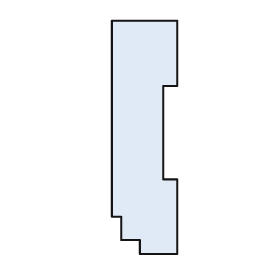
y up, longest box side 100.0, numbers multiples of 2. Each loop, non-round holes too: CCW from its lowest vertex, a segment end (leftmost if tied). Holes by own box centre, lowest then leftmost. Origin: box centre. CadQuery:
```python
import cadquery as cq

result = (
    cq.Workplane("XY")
    .moveTo(-2.0, -50.0)
    .lineTo(14.0, -50.0)
    .lineTo(14.0, -18.0)
    .lineTo(8.0, -18.0)
    .lineTo(8.0, 22.0)
    .lineTo(14.0, 22.0)
    .lineTo(14.0, 50.0)
    .lineTo(-14.0, 50.0)
    .lineTo(-14.0, -34.0)
    .lineTo(-10.0, -34.0)
    .lineTo(-10.0, -44.0)
    .lineTo(-2.0, -44.0)
    .close()
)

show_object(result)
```